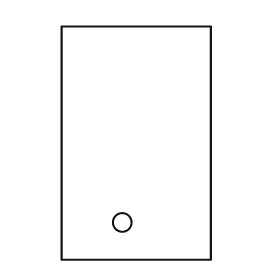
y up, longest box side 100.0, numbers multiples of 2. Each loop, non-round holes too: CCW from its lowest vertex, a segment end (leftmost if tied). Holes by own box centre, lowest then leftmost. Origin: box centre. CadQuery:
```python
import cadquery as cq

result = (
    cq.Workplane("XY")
    .moveTo(-32.0, -50.0)
    .lineTo(32.0, -50.0)
    .lineTo(32.0, 50.0)
    .lineTo(-32.0, 50.0)
    .close()
    .moveTo(-6.0, -34.0)
    .circle(4.0)
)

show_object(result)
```